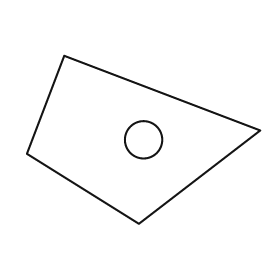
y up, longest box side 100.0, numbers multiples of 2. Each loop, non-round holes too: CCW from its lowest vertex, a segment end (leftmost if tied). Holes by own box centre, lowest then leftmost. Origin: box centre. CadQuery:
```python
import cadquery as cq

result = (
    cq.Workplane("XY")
    .moveTo(-2.0, -36.0)
    .lineTo(50.0, 4.0)
    .lineTo(-34.0, 36.0)
    .lineTo(-50.0, -6.0)
    .close()
    .moveTo(0.0, 0.0)
    .circle(8.0)
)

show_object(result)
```